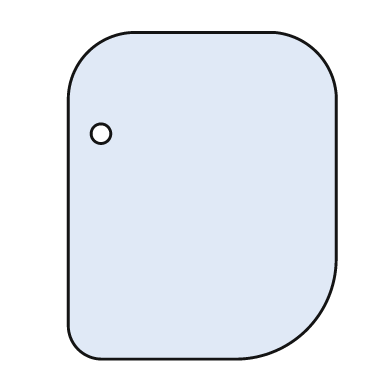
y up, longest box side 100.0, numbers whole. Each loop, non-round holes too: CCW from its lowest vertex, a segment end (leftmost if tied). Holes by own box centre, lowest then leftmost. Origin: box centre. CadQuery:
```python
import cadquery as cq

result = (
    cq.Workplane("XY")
    .moveTo(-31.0, -50.0)
    .lineTo(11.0, -50.0)
    .threePointArc((32.0, -41.0), (41.0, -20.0))
    .lineTo(41.0, 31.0)
    .threePointArc((35.0, 44.0), (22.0, 50.0))
    .lineTo(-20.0, 50.0)
    .threePointArc((-35.0, 44.0), (-41.0, 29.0))
    .lineTo(-41.0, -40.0)
    .threePointArc((-38.0, -47.0), (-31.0, -50.0))
    .close()
    .moveTo(-31.0, 19.0)
    .circle(3.0)
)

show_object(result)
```